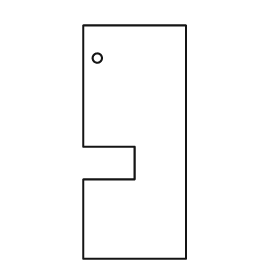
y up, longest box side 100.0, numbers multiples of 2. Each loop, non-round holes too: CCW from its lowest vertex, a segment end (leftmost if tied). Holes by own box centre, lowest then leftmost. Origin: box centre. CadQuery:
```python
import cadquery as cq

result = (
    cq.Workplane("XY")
    .moveTo(-22.0, -50.0)
    .lineTo(22.0, -50.0)
    .lineTo(22.0, 50.0)
    .lineTo(-22.0, 50.0)
    .lineTo(-22.0, -2.0)
    .lineTo(0.0, -2.0)
    .lineTo(0.0, -16.0)
    .lineTo(-22.0, -16.0)
    .close()
    .moveTo(-16.0, 36.0)
    .circle(2.0)
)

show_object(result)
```